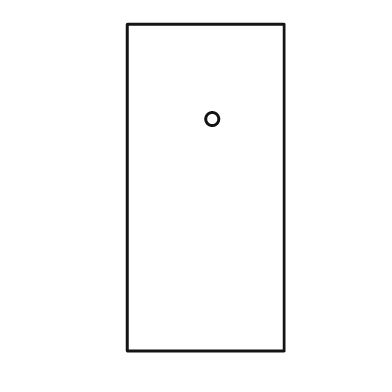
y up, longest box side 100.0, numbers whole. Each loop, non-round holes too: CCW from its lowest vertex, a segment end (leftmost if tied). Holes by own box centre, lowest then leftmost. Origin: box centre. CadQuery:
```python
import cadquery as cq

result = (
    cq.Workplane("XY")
    .moveTo(-24.0, -50.0)
    .lineTo(24.0, -50.0)
    .lineTo(24.0, 50.0)
    .lineTo(-24.0, 50.0)
    .close()
    .moveTo(2.0, 21.0)
    .circle(2.0)
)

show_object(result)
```